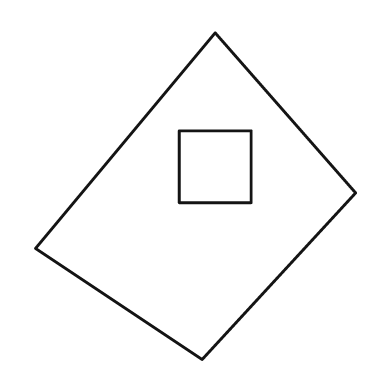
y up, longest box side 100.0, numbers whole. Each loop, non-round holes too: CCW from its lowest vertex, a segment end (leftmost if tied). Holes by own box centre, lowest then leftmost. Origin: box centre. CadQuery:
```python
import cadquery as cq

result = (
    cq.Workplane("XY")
    .moveTo(2.0, -50.0)
    .lineTo(49.0, 1.0)
    .lineTo(6.0, 50.0)
    .lineTo(-49.0, -16.0)
    .close()
    .moveTo(-5.0, -2.0)
    .lineTo(17.0, -2.0)
    .lineTo(17.0, 20.0)
    .lineTo(-5.0, 20.0)
    .close()
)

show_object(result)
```